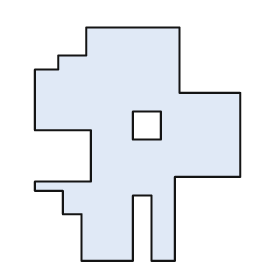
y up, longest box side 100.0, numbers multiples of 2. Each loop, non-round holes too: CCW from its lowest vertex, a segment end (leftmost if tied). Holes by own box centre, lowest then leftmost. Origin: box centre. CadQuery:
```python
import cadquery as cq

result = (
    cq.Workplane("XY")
    .moveTo(-24.0, -50.0)
    .lineTo(-2.0, -50.0)
    .lineTo(-2.0, -22.0)
    .lineTo(6.0, -22.0)
    .lineTo(6.0, -50.0)
    .lineTo(16.0, -50.0)
    .lineTo(16.0, -14.0)
    .lineTo(44.0, -14.0)
    .lineTo(44.0, 22.0)
    .lineTo(18.0, 22.0)
    .lineTo(18.0, 50.0)
    .lineTo(-22.0, 50.0)
    .lineTo(-22.0, 38.0)
    .lineTo(-34.0, 38.0)
    .lineTo(-34.0, 32.0)
    .lineTo(-44.0, 32.0)
    .lineTo(-44.0, 6.0)
    .lineTo(-20.0, 6.0)
    .lineTo(-20.0, -16.0)
    .lineTo(-44.0, -16.0)
    .lineTo(-44.0, -20.0)
    .lineTo(-32.0, -20.0)
    .lineTo(-32.0, -30.0)
    .lineTo(-24.0, -30.0)
    .close()
    .moveTo(-2.0, 2.0)
    .lineTo(10.0, 2.0)
    .lineTo(10.0, 14.0)
    .lineTo(-2.0, 14.0)
    .close()
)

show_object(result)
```